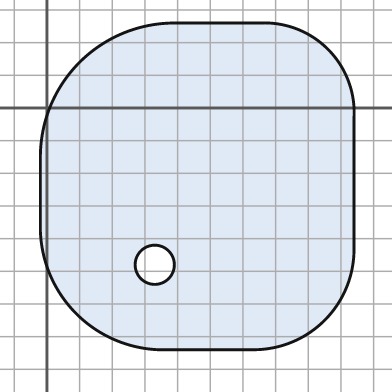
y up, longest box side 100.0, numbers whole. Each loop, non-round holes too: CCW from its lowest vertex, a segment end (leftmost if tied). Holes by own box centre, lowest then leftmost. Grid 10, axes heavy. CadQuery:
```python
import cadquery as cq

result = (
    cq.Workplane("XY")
    .moveTo(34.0, -74.0)
    .lineTo(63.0, -74.0)
    .threePointArc((85.0, -65.0), (94.0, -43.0))
    .lineTo(94.0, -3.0)
    .threePointArc((86.0, 18.0), (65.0, 26.0))
    .lineTo(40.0, 26.0)
    .threePointArc((10.0, 14.0), (-2.0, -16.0))
    .lineTo(-2.0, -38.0)
    .threePointArc((9.0, -63.0), (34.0, -74.0))
    .close()
    .moveTo(33.0, -48.0)
    .circle(6.0)
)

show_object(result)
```